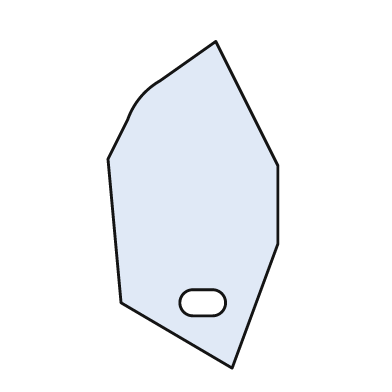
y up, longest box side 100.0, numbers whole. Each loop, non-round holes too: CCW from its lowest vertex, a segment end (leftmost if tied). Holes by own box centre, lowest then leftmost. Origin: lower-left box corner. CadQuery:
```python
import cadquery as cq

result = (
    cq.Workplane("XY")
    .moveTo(38.0, 0.0)
    .lineTo(52.0, 38.0)
    .lineTo(52.0, 62.0)
    .lineTo(33.0, 100.0)
    .lineTo(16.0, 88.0)
    .threePointArc((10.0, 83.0), (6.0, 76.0))
    .lineTo(0.0, 64.0)
    .lineTo(4.0, 20.0)
    .close()
    .moveTo(26.0, 16.0)
    .lineTo(32.0, 16.0)
    .threePointArc((36.0, 20.0), (32.0, 24.0))
    .lineTo(26.0, 24.0)
    .threePointArc((22.0, 20.0), (26.0, 16.0))
    .close()
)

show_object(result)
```